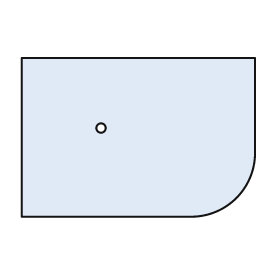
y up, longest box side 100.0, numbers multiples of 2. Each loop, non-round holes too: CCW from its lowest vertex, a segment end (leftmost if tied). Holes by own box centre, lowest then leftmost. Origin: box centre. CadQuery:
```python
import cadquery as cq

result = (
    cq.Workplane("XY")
    .moveTo(-50.0, -34.0)
    .lineTo(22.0, -34.0)
    .threePointArc((42.0, -26.0), (50.0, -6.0))
    .lineTo(50.0, 34.0)
    .lineTo(-50.0, 34.0)
    .close()
    .moveTo(-16.0, 4.0)
    .circle(2.0)
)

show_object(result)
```